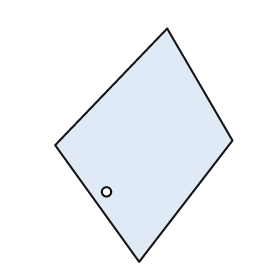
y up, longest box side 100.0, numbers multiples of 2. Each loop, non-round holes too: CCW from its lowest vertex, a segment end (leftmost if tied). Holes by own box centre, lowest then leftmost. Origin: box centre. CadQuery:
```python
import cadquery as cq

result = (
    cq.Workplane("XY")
    .moveTo(-2.0, -50.0)
    .lineTo(38.0, 2.0)
    .lineTo(10.0, 50.0)
    .lineTo(-38.0, 0.0)
    .close()
    .moveTo(-16.0, -20.0)
    .circle(2.0)
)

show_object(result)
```